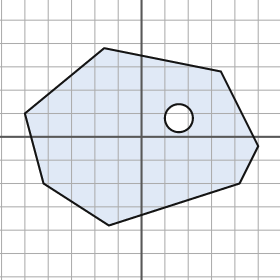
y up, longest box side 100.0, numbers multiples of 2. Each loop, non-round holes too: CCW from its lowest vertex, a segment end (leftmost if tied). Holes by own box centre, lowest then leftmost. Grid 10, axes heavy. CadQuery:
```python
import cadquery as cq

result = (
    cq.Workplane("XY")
    .moveTo(-14.0, -38.0)
    .lineTo(42.0, -20.0)
    .lineTo(50.0, -4.0)
    .lineTo(34.0, 28.0)
    .lineTo(-16.0, 38.0)
    .lineTo(-50.0, 10.0)
    .lineTo(-42.0, -20.0)
    .close()
    .moveTo(16.0, 8.0)
    .circle(6.0)
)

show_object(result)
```